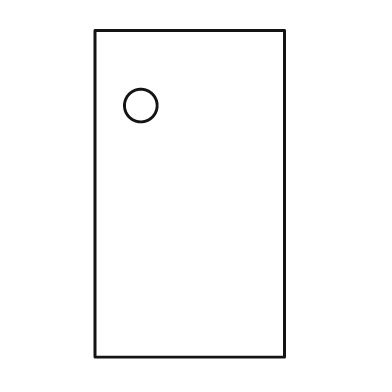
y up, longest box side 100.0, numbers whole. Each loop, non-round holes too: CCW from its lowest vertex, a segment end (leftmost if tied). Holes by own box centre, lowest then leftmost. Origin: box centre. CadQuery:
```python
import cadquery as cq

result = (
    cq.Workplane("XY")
    .moveTo(-29.0, -50.0)
    .lineTo(29.0, -50.0)
    .lineTo(29.0, 50.0)
    .lineTo(-29.0, 50.0)
    .close()
    .moveTo(-15.0, 27.0)
    .circle(5.0)
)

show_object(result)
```